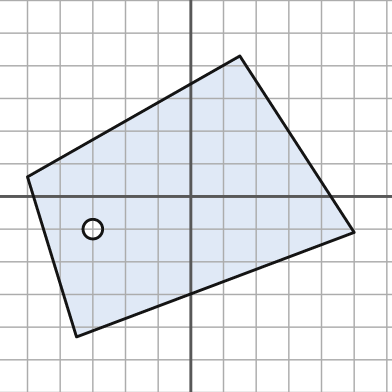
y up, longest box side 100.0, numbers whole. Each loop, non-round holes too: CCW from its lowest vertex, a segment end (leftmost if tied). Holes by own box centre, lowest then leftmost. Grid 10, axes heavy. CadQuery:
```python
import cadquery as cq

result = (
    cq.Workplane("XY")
    .moveTo(-35.0, -43.0)
    .lineTo(50.0, -11.0)
    .lineTo(15.0, 43.0)
    .lineTo(-50.0, 6.0)
    .close()
    .moveTo(-30.0, -10.0)
    .circle(3.0)
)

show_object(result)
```